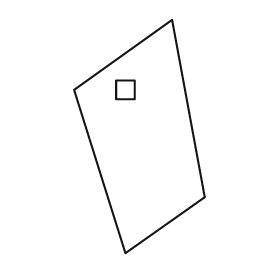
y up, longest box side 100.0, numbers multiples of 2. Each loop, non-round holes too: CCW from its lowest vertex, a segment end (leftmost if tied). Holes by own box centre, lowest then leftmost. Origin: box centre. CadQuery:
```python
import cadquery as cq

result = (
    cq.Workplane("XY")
    .moveTo(-6.0, -50.0)
    .lineTo(28.0, -26.0)
    .lineTo(14.0, 50.0)
    .lineTo(-28.0, 20.0)
    .close()
    .moveTo(-10.0, 16.0)
    .lineTo(-2.0, 16.0)
    .lineTo(-2.0, 24.0)
    .lineTo(-10.0, 24.0)
    .close()
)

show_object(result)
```